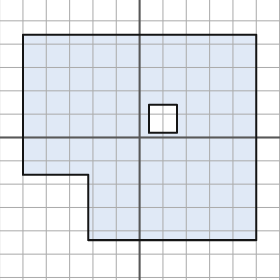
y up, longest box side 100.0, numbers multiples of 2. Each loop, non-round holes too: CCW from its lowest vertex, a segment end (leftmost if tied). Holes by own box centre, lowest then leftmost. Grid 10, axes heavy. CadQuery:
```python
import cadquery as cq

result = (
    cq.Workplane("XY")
    .moveTo(-22.0, -44.0)
    .lineTo(50.0, -44.0)
    .lineTo(50.0, 44.0)
    .lineTo(-50.0, 44.0)
    .lineTo(-50.0, -16.0)
    .lineTo(-22.0, -16.0)
    .close()
    .moveTo(4.0, 2.0)
    .lineTo(16.0, 2.0)
    .lineTo(16.0, 14.0)
    .lineTo(4.0, 14.0)
    .close()
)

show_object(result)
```